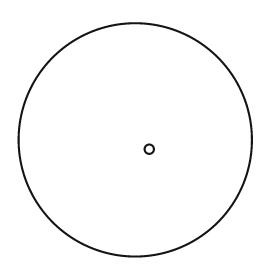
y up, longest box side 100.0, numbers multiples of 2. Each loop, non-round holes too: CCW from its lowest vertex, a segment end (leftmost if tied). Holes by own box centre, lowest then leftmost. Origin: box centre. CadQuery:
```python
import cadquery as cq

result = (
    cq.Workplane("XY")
    .moveTo(0.0, 0.0)
    .circle(50.0)
    .moveTo(6.0, -4.0)
    .circle(2.0)
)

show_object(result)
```